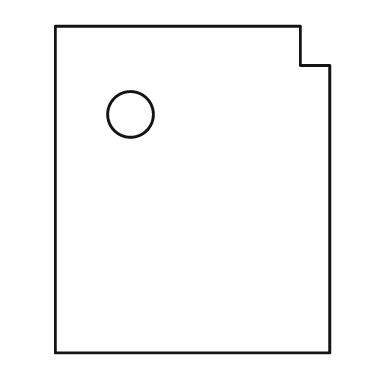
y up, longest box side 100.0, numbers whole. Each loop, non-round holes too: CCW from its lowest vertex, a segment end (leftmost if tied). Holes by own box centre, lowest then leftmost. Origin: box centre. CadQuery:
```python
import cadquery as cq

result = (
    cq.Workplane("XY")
    .moveTo(-42.0, -50.0)
    .lineTo(42.0, -50.0)
    .lineTo(42.0, 38.0)
    .lineTo(33.0, 38.0)
    .lineTo(33.0, 50.0)
    .lineTo(-42.0, 50.0)
    .close()
    .moveTo(-19.0, 23.0)
    .circle(7.0)
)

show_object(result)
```